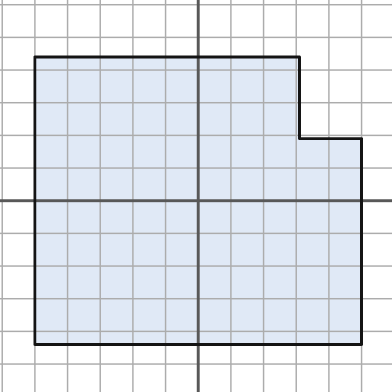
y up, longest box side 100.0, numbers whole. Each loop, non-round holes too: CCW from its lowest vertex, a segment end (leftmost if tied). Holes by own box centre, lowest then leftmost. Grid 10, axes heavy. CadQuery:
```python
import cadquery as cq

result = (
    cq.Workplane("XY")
    .moveTo(-50.0, -44.0)
    .lineTo(50.0, -44.0)
    .lineTo(50.0, 19.0)
    .lineTo(31.0, 19.0)
    .lineTo(31.0, 44.0)
    .lineTo(-50.0, 44.0)
    .close()
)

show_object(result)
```